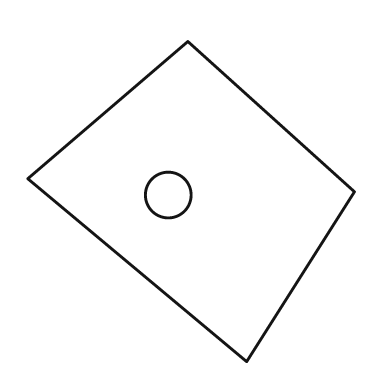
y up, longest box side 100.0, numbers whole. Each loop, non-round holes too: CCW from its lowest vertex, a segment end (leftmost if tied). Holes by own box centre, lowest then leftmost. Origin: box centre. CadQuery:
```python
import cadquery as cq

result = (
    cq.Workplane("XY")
    .moveTo(17.0, -49.0)
    .lineTo(50.0, 3.0)
    .lineTo(-1.0, 49.0)
    .lineTo(-50.0, 7.0)
    .close()
    .moveTo(-7.0, 2.0)
    .circle(7.0)
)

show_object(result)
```